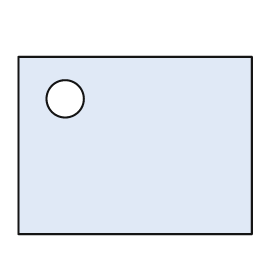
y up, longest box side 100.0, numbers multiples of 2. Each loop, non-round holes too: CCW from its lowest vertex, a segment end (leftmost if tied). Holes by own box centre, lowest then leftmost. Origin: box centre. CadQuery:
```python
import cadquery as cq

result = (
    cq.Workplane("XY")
    .moveTo(-50.0, -38.0)
    .lineTo(50.0, -38.0)
    .lineTo(50.0, 38.0)
    .lineTo(-50.0, 38.0)
    .close()
    .moveTo(-30.0, 20.0)
    .circle(8.0)
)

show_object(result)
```